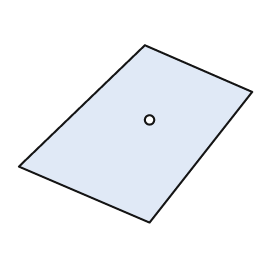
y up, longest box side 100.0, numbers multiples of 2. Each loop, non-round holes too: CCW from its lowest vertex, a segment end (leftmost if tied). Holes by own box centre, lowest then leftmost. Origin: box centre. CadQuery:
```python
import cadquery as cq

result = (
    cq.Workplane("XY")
    .moveTo(6.0, -38.0)
    .lineTo(50.0, 18.0)
    .lineTo(4.0, 38.0)
    .lineTo(-50.0, -14.0)
    .close()
    .moveTo(6.0, 6.0)
    .circle(2.0)
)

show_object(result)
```